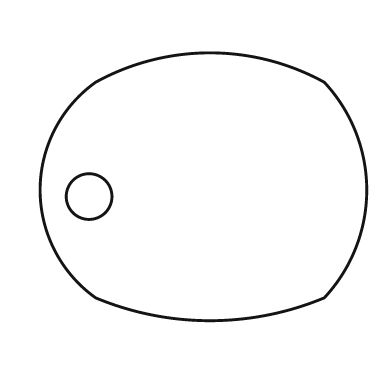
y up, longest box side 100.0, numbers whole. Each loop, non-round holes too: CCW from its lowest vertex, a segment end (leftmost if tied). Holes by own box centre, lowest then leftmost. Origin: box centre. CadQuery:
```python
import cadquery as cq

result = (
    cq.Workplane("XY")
    .moveTo(-33.0, -34.0)
    .threePointArc((2.0, -41.0), (37.0, -34.0))
    .threePointArc((50.0, -1.0), (37.0, 32.0))
    .threePointArc((2.0, 41.0), (-33.0, 32.0))
    .threePointArc((-50.0, -1.0), (-33.0, -34.0))
    .close()
    .moveTo(-35.0, -3.0)
    .circle(7.0)
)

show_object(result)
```